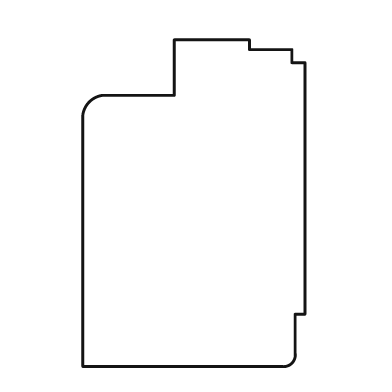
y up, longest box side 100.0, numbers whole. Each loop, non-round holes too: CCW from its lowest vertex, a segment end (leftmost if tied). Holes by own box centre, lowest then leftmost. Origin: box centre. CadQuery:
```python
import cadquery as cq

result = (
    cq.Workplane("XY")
    .moveTo(-34.0, -50.0)
    .lineTo(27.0, -50.0)
    .threePointArc((30.0, -49.0), (31.0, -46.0))
    .lineTo(31.0, -34.0)
    .lineTo(34.0, -34.0)
    .lineTo(34.0, 43.0)
    .lineTo(30.0, 43.0)
    .lineTo(30.0, 47.0)
    .lineTo(17.0, 47.0)
    .lineTo(17.0, 50.0)
    .lineTo(-6.0, 50.0)
    .lineTo(-6.0, 33.0)
    .lineTo(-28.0, 33.0)
    .threePointArc((-32.0, 31.0), (-34.0, 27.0))
    .close()
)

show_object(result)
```